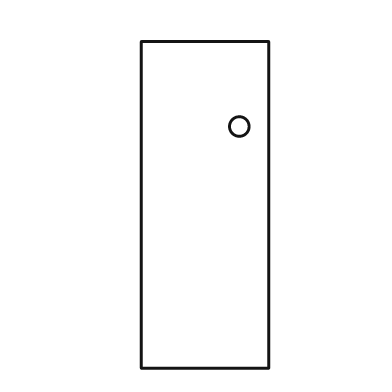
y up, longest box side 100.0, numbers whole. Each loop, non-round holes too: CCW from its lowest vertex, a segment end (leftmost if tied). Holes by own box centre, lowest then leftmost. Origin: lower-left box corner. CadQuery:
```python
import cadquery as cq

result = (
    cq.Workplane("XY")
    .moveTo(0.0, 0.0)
    .lineTo(39.0, 0.0)
    .lineTo(39.0, 100.0)
    .lineTo(0.0, 100.0)
    .close()
    .moveTo(30.0, 74.0)
    .circle(3.0)
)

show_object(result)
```